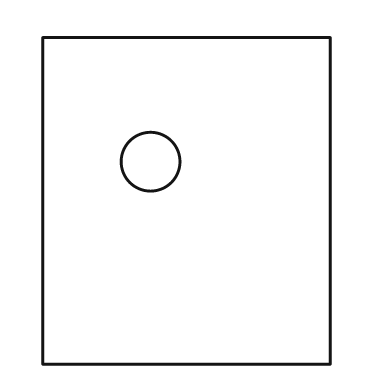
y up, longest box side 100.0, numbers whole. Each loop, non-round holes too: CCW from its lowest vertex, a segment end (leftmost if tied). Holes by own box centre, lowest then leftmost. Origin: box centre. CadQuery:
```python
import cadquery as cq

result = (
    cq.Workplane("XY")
    .moveTo(-44.0, -50.0)
    .lineTo(44.0, -50.0)
    .lineTo(44.0, 50.0)
    .lineTo(-44.0, 50.0)
    .close()
    .moveTo(-11.0, 12.0)
    .circle(9.0)
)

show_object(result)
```